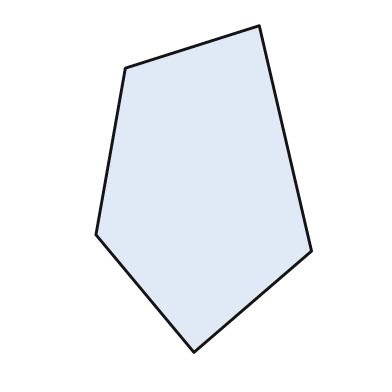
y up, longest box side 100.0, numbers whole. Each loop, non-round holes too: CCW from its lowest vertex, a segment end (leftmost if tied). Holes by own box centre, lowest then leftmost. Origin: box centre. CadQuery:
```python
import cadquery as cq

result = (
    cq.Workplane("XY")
    .moveTo(-3.0, -50.0)
    .lineTo(33.0, -19.0)
    .lineTo(17.0, 50.0)
    .lineTo(-24.0, 37.0)
    .lineTo(-33.0, -14.0)
    .close()
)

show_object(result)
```